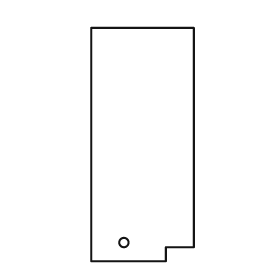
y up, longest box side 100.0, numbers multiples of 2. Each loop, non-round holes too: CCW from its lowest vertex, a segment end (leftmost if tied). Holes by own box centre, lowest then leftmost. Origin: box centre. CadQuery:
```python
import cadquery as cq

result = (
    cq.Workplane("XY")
    .moveTo(-22.0, -50.0)
    .lineTo(10.0, -50.0)
    .lineTo(10.0, -44.0)
    .lineTo(22.0, -44.0)
    .lineTo(22.0, 50.0)
    .lineTo(-22.0, 50.0)
    .close()
    .moveTo(-8.0, -42.0)
    .circle(2.0)
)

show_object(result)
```